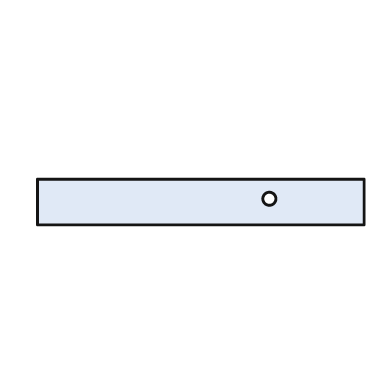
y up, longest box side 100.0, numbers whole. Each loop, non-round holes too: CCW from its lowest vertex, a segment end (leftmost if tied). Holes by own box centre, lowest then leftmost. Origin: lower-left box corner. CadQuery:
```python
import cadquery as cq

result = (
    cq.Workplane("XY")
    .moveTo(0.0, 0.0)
    .lineTo(100.0, 0.0)
    .lineTo(100.0, 14.0)
    .lineTo(0.0, 14.0)
    .close()
    .moveTo(71.0, 8.0)
    .circle(2.0)
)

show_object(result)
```